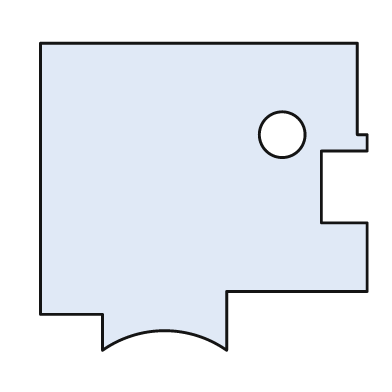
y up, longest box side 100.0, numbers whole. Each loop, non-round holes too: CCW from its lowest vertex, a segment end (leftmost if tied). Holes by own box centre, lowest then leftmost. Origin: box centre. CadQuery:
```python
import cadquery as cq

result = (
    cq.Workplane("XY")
    .moveTo(-31.0, -47.0)
    .threePointArc((-12.0, -41.0), (7.0, -47.0))
    .lineTo(7.0, -29.0)
    .lineTo(50.0, -29.0)
    .lineTo(50.0, -8.0)
    .lineTo(36.0, -8.0)
    .lineTo(36.0, 14.0)
    .lineTo(50.0, 14.0)
    .lineTo(50.0, 19.0)
    .lineTo(47.0, 19.0)
    .lineTo(47.0, 47.0)
    .lineTo(-50.0, 47.0)
    .lineTo(-50.0, -36.0)
    .lineTo(-31.0, -36.0)
    .close()
    .moveTo(24.0, 19.0)
    .circle(7.0)
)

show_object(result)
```